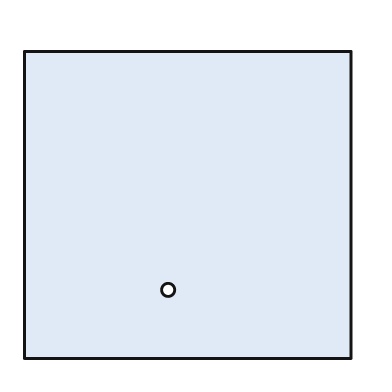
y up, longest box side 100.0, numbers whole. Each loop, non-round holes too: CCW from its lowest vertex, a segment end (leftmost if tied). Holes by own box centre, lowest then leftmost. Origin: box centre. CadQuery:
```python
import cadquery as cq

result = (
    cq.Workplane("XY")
    .moveTo(-50.0, -47.0)
    .lineTo(50.0, -47.0)
    .lineTo(50.0, 47.0)
    .lineTo(-50.0, 47.0)
    .close()
    .moveTo(-6.0, -26.0)
    .circle(2.0)
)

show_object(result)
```